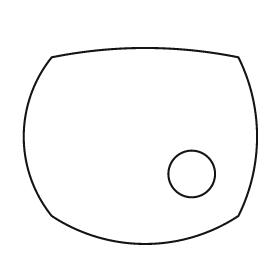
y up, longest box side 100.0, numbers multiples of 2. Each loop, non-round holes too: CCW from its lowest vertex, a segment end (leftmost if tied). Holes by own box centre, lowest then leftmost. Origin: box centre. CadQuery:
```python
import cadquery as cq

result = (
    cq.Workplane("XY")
    .moveTo(-38.0, -30.0)
    .threePointArc((2.0, -42.0), (42.0, -30.0))
    .threePointArc((50.0, 4.0), (42.0, 38.0))
    .threePointArc((2.0, 42.0), (-38.0, 38.0))
    .threePointArc((-50.0, 4.0), (-38.0, -30.0))
    .close()
    .moveTo(22.0, -12.0)
    .circle(10.0)
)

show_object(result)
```